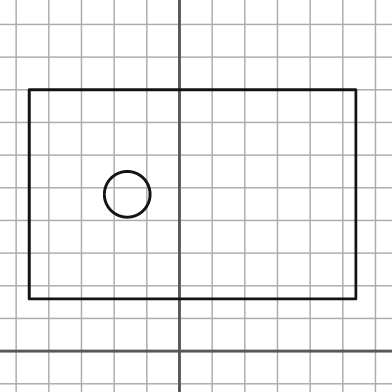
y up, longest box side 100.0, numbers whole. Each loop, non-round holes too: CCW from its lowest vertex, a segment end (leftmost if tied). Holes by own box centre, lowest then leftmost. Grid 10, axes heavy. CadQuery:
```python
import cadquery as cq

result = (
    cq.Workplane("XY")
    .moveTo(-46.0, 16.0)
    .lineTo(54.0, 16.0)
    .lineTo(54.0, 80.0)
    .lineTo(-46.0, 80.0)
    .close()
    .moveTo(-16.0, 48.0)
    .circle(7.0)
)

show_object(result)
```